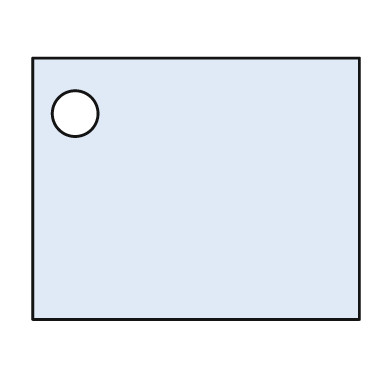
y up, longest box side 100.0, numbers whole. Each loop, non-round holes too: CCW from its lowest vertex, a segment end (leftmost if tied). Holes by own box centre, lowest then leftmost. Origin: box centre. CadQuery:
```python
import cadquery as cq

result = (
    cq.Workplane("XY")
    .moveTo(-50.0, -40.0)
    .lineTo(50.0, -40.0)
    .lineTo(50.0, 40.0)
    .lineTo(-50.0, 40.0)
    .close()
    .moveTo(-37.0, 23.0)
    .circle(7.0)
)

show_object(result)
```